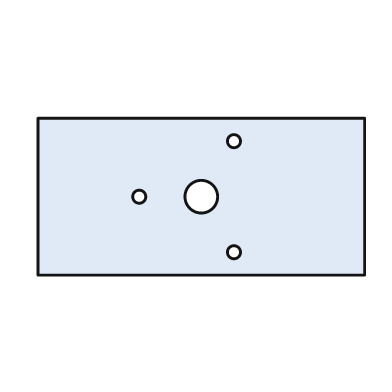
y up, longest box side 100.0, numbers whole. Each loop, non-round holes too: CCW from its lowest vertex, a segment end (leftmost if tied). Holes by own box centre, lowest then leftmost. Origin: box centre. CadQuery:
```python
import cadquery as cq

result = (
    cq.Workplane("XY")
    .moveTo(-50.0, -24.0)
    .lineTo(50.0, -24.0)
    .lineTo(50.0, 24.0)
    .lineTo(-50.0, 24.0)
    .close()
    .moveTo(10.0, -17.0)
    .circle(2.0)
    .moveTo(-19.0, 0.0)
    .circle(2.0)
    .moveTo(0.0, 0.0)
    .circle(5.0)
    .moveTo(10.0, 17.0)
    .circle(2.0)
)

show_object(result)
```